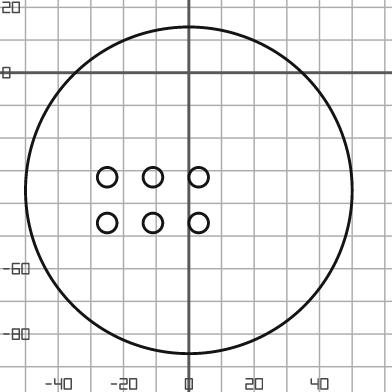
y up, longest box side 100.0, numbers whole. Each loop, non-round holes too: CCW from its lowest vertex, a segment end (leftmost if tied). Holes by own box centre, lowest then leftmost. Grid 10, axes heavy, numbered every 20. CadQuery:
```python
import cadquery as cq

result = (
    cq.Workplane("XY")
    .moveTo(0.0, -36.0)
    .circle(50.0)
    .moveTo(-25.0, -46.0)
    .circle(3.0)
    .moveTo(-11.0, -46.0)
    .circle(3.0)
    .moveTo(3.0, -46.0)
    .circle(3.0)
    .moveTo(-25.0, -32.0)
    .circle(3.0)
    .moveTo(-11.0, -32.0)
    .circle(3.0)
    .moveTo(3.0, -32.0)
    .circle(3.0)
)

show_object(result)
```